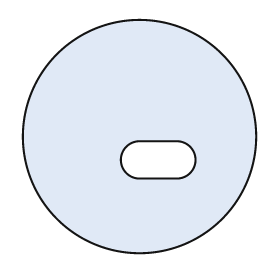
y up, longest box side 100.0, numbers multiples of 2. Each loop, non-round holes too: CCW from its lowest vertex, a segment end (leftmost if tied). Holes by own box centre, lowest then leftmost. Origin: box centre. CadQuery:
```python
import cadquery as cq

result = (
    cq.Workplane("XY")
    .moveTo(0.0, 0.0)
    .circle(50.0)
    .moveTo(0.0, -18.0)
    .lineTo(16.0, -18.0)
    .threePointArc((24.0, -10.0), (16.0, -2.0))
    .lineTo(0.0, -2.0)
    .threePointArc((-8.0, -10.0), (0.0, -18.0))
    .close()
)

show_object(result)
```